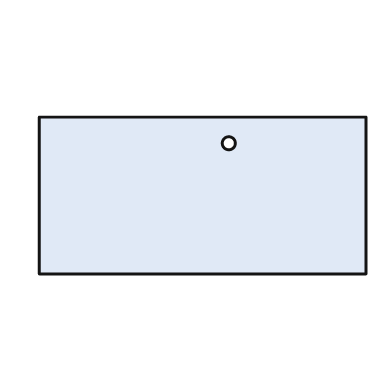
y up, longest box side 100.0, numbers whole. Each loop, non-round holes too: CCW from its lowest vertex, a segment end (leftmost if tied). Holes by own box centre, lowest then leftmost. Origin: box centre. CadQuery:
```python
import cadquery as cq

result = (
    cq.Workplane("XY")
    .moveTo(-50.0, -24.0)
    .lineTo(50.0, -24.0)
    .lineTo(50.0, 24.0)
    .lineTo(-50.0, 24.0)
    .close()
    .moveTo(8.0, 16.0)
    .circle(2.0)
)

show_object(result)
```